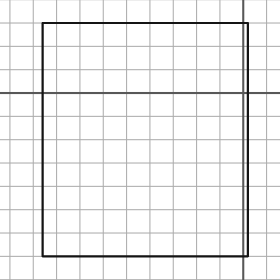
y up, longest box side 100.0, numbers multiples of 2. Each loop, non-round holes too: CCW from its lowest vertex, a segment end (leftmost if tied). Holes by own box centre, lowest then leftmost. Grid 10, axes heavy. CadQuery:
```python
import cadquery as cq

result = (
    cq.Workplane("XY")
    .moveTo(-86.0, -70.0)
    .lineTo(2.0, -70.0)
    .lineTo(2.0, 30.0)
    .lineTo(-86.0, 30.0)
    .close()
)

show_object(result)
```